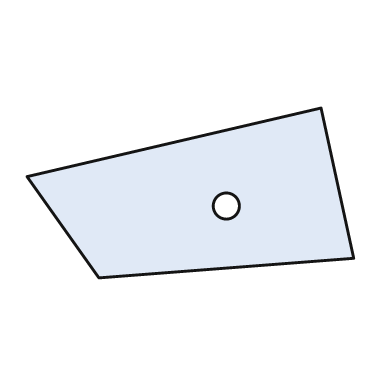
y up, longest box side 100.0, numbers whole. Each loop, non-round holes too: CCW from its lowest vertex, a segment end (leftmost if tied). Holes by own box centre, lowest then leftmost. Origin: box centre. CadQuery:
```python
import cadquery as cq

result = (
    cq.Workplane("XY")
    .moveTo(-28.0, -26.0)
    .lineTo(50.0, -20.0)
    .lineTo(40.0, 26.0)
    .lineTo(-50.0, 5.0)
    .close()
    .moveTo(11.0, -4.0)
    .circle(4.0)
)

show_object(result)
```